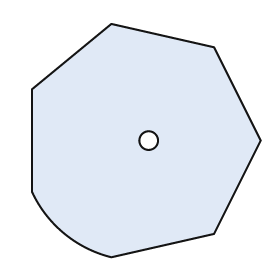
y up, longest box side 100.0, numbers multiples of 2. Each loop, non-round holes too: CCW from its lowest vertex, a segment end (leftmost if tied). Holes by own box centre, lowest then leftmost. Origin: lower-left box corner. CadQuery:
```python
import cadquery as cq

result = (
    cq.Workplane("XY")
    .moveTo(34.0, 0.0)
    .lineTo(78.0, 10.0)
    .lineTo(98.0, 50.0)
    .lineTo(78.0, 90.0)
    .lineTo(34.0, 100.0)
    .lineTo(0.0, 72.0)
    .lineTo(0.0, 28.0)
    .threePointArc((14.0, 10.0), (34.0, 0.0))
    .close()
    .moveTo(50.0, 50.0)
    .circle(4.0)
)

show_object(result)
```